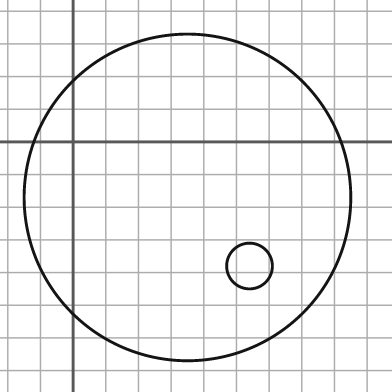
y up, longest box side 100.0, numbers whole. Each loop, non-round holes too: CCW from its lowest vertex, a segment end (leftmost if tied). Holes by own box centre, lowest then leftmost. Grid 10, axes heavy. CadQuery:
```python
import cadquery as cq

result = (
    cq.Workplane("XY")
    .moveTo(35.0, -17.0)
    .circle(50.0)
    .moveTo(54.0, -38.0)
    .circle(7.0)
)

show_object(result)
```